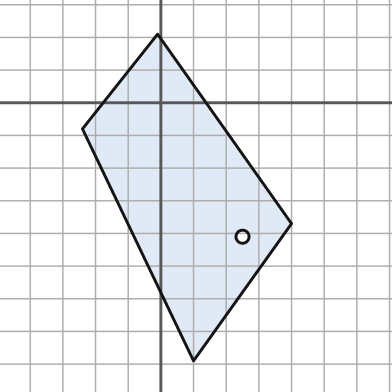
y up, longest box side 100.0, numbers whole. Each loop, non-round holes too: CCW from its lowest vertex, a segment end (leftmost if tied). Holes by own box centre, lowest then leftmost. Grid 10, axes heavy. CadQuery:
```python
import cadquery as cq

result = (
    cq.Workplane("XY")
    .moveTo(10.0, -79.0)
    .lineTo(40.0, -37.0)
    .lineTo(-1.0, 21.0)
    .lineTo(-24.0, -8.0)
    .close()
    .moveTo(25.0, -41.0)
    .circle(2.0)
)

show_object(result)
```